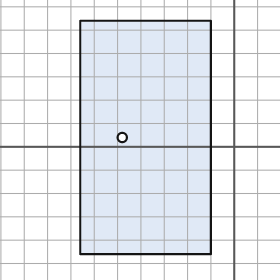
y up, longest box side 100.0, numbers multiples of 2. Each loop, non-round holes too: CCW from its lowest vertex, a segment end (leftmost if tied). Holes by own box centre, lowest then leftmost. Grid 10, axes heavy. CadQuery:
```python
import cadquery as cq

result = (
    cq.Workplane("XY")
    .moveTo(-66.0, -46.0)
    .lineTo(-10.0, -46.0)
    .lineTo(-10.0, 54.0)
    .lineTo(-66.0, 54.0)
    .close()
    .moveTo(-48.0, 4.0)
    .circle(2.0)
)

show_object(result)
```